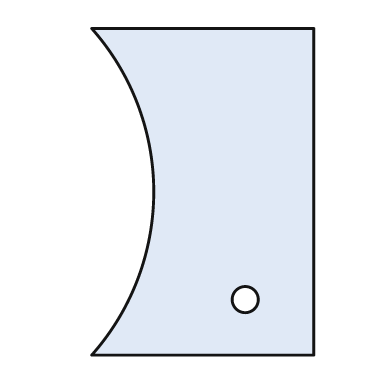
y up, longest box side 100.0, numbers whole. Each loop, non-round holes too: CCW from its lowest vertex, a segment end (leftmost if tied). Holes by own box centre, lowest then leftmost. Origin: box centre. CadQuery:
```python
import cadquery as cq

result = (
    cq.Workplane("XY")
    .moveTo(-34.0, -50.0)
    .lineTo(34.0, -50.0)
    .lineTo(34.0, 50.0)
    .lineTo(-34.0, 50.0)
    .threePointArc((-15.0, 0.0), (-34.0, -50.0))
    .close()
    .moveTo(13.0, -33.0)
    .circle(4.0)
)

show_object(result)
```